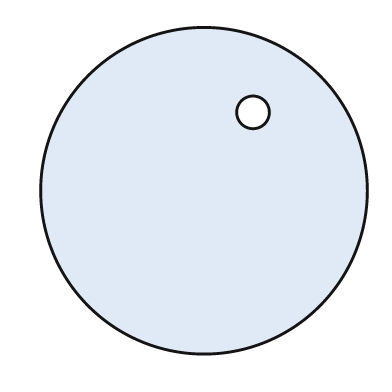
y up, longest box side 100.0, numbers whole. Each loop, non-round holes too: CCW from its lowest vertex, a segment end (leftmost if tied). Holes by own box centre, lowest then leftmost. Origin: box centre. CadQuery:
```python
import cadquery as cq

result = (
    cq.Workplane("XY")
    .moveTo(0.0, 0.0)
    .circle(50.0)
    .moveTo(15.0, 24.0)
    .circle(5.0)
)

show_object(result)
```